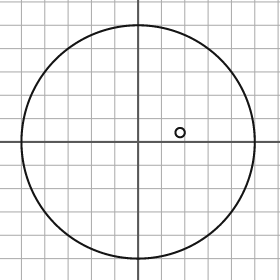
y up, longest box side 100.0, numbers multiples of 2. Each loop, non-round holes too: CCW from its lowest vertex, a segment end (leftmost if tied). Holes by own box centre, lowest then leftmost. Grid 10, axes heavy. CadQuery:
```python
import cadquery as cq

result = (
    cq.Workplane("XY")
    .moveTo(0.0, 0.0)
    .circle(50.0)
    .moveTo(18.0, 4.0)
    .circle(2.0)
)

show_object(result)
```